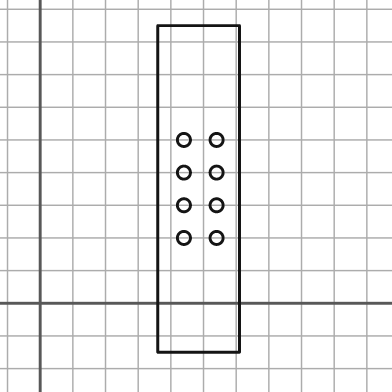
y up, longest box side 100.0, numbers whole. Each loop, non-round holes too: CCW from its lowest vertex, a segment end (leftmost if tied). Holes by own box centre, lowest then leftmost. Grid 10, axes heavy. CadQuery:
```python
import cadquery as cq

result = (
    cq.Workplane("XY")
    .moveTo(36.0, -15.0)
    .lineTo(61.0, -15.0)
    .lineTo(61.0, 85.0)
    .lineTo(36.0, 85.0)
    .close()
    .moveTo(44.0, 20.0)
    .circle(2.0)
    .moveTo(54.0, 20.0)
    .circle(2.0)
    .moveTo(44.0, 30.0)
    .circle(2.0)
    .moveTo(54.0, 30.0)
    .circle(2.0)
    .moveTo(44.0, 40.0)
    .circle(2.0)
    .moveTo(54.0, 40.0)
    .circle(2.0)
    .moveTo(44.0, 50.0)
    .circle(2.0)
    .moveTo(54.0, 50.0)
    .circle(2.0)
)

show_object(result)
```